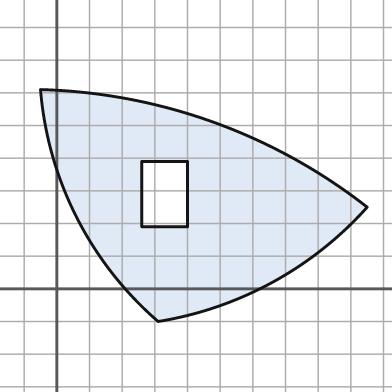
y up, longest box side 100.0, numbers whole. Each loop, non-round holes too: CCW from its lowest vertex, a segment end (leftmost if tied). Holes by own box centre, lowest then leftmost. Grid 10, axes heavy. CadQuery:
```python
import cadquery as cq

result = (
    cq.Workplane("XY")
    .moveTo(31.0, -10.0)
    .threePointArc((66.0, 2.0), (95.0, 25.0))
    .threePointArc((48.0, 51.0), (-5.0, 61.0))
    .threePointArc((6.0, 22.0), (31.0, -10.0))
    .close()
    .moveTo(26.0, 19.0)
    .lineTo(40.0, 19.0)
    .lineTo(40.0, 39.0)
    .lineTo(26.0, 39.0)
    .close()
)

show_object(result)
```